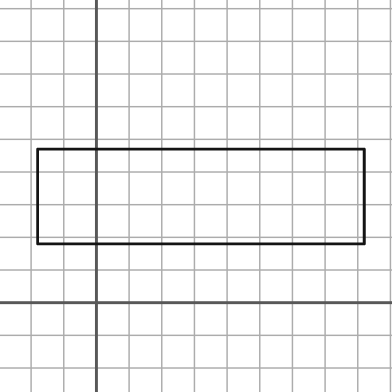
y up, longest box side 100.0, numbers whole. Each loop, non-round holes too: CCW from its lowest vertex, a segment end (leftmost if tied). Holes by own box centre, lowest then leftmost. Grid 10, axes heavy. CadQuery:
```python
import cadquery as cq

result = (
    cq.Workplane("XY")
    .moveTo(-18.0, 18.0)
    .lineTo(82.0, 18.0)
    .lineTo(82.0, 47.0)
    .lineTo(-18.0, 47.0)
    .close()
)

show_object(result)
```